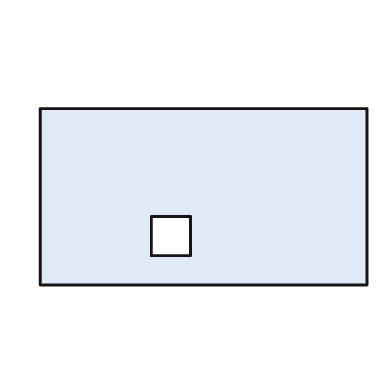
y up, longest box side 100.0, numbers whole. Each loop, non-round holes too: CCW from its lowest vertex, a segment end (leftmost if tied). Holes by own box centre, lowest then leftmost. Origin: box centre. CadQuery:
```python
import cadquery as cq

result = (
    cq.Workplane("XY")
    .moveTo(-50.0, -27.0)
    .lineTo(50.0, -27.0)
    .lineTo(50.0, 27.0)
    .lineTo(-50.0, 27.0)
    .close()
    .moveTo(-16.0, -18.0)
    .lineTo(-4.0, -18.0)
    .lineTo(-4.0, -6.0)
    .lineTo(-16.0, -6.0)
    .close()
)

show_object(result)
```